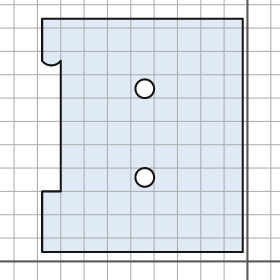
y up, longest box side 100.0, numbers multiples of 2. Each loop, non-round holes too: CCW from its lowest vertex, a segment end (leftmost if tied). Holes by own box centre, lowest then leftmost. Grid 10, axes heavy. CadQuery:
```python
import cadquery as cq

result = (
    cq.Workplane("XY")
    .moveTo(-88.0, 4.0)
    .lineTo(-2.0, 4.0)
    .lineTo(-2.0, 104.0)
    .lineTo(-88.0, 104.0)
    .lineTo(-88.0, 86.0)
    .threePointArc((-84.0, 84.0), (-80.0, 86.0))
    .lineTo(-80.0, 30.0)
    .lineTo(-88.0, 30.0)
    .close()
    .moveTo(-44.0, 36.0)
    .circle(4.0)
    .moveTo(-44.0, 74.0)
    .circle(4.0)
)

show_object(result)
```